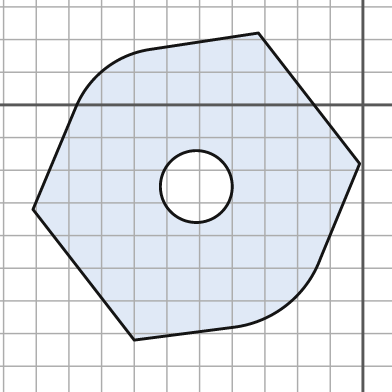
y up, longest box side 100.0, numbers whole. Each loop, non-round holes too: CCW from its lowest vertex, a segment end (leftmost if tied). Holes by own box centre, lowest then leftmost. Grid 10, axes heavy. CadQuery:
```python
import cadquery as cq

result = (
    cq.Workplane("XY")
    .moveTo(-70.0, -72.0)
    .lineTo(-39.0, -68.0)
    .threePointArc((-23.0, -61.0), (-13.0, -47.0))
    .lineTo(-1.0, -18.0)
    .lineTo(-32.0, 22.0)
    .lineTo(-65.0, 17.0)
    .threePointArc((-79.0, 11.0), (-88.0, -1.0))
    .lineTo(-101.0, -32.0)
    .close()
    .moveTo(-51.0, -25.0)
    .circle(11.0)
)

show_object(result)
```